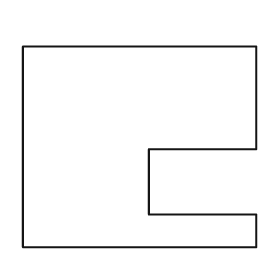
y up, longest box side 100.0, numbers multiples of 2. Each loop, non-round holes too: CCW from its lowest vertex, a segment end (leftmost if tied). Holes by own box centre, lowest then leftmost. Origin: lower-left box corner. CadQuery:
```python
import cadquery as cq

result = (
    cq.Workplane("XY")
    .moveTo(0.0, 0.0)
    .lineTo(100.0, 0.0)
    .lineTo(100.0, 14.0)
    .lineTo(54.0, 14.0)
    .lineTo(54.0, 42.0)
    .lineTo(100.0, 42.0)
    .lineTo(100.0, 86.0)
    .lineTo(0.0, 86.0)
    .close()
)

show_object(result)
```